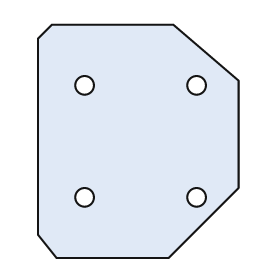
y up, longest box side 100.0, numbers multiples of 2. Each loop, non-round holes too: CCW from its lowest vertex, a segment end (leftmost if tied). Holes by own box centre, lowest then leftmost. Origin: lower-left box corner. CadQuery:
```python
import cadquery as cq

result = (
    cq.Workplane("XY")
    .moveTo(8.0, 0.0)
    .lineTo(56.0, 0.0)
    .lineTo(86.0, 30.0)
    .lineTo(86.0, 76.0)
    .lineTo(58.0, 100.0)
    .lineTo(6.0, 100.0)
    .lineTo(0.0, 94.0)
    .lineTo(0.0, 10.0)
    .close()
    .moveTo(20.0, 26.0)
    .circle(4.0)
    .moveTo(68.0, 26.0)
    .circle(4.0)
    .moveTo(20.0, 74.0)
    .circle(4.0)
    .moveTo(68.0, 74.0)
    .circle(4.0)
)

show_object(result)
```